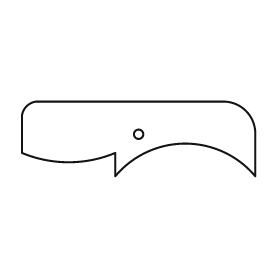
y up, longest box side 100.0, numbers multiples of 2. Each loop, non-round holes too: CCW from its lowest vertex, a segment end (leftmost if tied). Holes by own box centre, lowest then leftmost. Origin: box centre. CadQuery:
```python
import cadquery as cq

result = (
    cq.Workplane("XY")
    .moveTo(-10.0, -16.0)
    .threePointArc((20.0, -2.0), (50.0, -16.0))
    .lineTo(50.0, 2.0)
    .threePointArc((46.0, 12.0), (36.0, 16.0))
    .lineTo(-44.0, 16.0)
    .threePointArc((-48.0, 14.0), (-50.0, 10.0))
    .lineTo(-50.0, -6.0)
    .threePointArc((-30.0, -10.0), (-10.0, -6.0))
    .close()
    .moveTo(0.0, 2.0)
    .circle(2.0)
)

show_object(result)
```